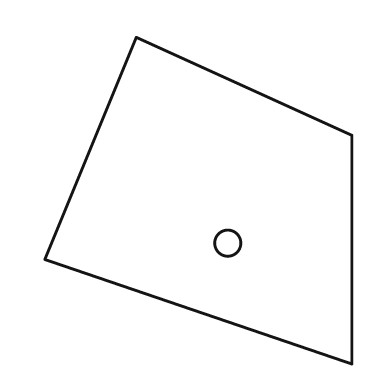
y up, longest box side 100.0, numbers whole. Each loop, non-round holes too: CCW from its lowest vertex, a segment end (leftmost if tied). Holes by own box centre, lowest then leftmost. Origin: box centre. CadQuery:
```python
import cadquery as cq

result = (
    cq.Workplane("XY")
    .moveTo(47.0, -50.0)
    .lineTo(47.0, 20.0)
    .lineTo(-19.0, 50.0)
    .lineTo(-47.0, -18.0)
    .close()
    .moveTo(9.0, -13.0)
    .circle(4.0)
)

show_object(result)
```